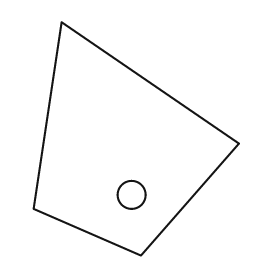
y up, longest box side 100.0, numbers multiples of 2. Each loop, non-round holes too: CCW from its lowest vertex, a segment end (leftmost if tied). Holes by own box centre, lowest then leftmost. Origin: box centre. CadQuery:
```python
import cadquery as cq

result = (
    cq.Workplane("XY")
    .moveTo(2.0, -50.0)
    .lineTo(44.0, -2.0)
    .lineTo(-32.0, 50.0)
    .lineTo(-44.0, -30.0)
    .close()
    .moveTo(-2.0, -24.0)
    .circle(6.0)
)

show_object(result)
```